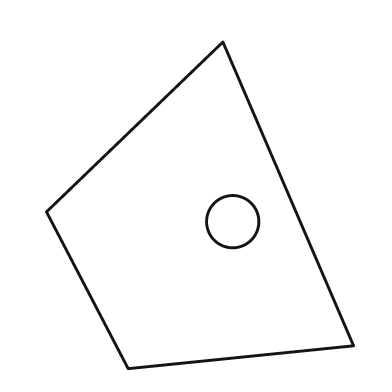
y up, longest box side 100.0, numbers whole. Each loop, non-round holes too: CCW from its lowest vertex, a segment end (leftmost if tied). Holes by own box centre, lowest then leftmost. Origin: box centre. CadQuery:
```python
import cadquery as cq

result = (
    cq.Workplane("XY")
    .moveTo(-22.0, -50.0)
    .lineTo(47.0, -43.0)
    .lineTo(7.0, 50.0)
    .lineTo(-47.0, -2.0)
    .close()
    .moveTo(10.0, -5.0)
    .circle(8.0)
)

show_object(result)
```